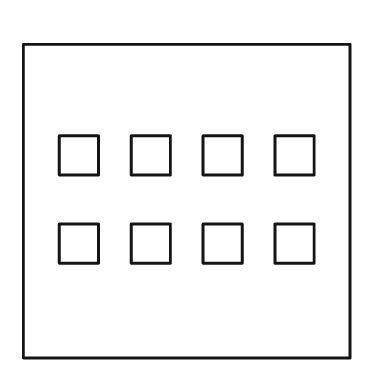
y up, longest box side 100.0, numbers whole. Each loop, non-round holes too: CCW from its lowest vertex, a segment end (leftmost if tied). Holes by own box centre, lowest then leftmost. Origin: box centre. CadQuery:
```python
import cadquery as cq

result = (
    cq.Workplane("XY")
    .moveTo(-50.0, -48.0)
    .lineTo(50.0, -48.0)
    .lineTo(50.0, 48.0)
    .lineTo(-50.0, 48.0)
    .close()
    .moveTo(-39.0, -19.0)
    .lineTo(-27.0, -19.0)
    .lineTo(-27.0, -7.0)
    .lineTo(-39.0, -7.0)
    .close()
    .moveTo(-17.0, -19.0)
    .lineTo(-5.0, -19.0)
    .lineTo(-5.0, -7.0)
    .lineTo(-17.0, -7.0)
    .close()
    .moveTo(5.0, -19.0)
    .lineTo(17.0, -19.0)
    .lineTo(17.0, -7.0)
    .lineTo(5.0, -7.0)
    .close()
    .moveTo(27.0, -19.0)
    .lineTo(39.0, -19.0)
    .lineTo(39.0, -7.0)
    .lineTo(27.0, -7.0)
    .close()
    .moveTo(-39.0, 8.0)
    .lineTo(-27.0, 8.0)
    .lineTo(-27.0, 20.0)
    .lineTo(-39.0, 20.0)
    .close()
    .moveTo(-17.0, 8.0)
    .lineTo(-5.0, 8.0)
    .lineTo(-5.0, 20.0)
    .lineTo(-17.0, 20.0)
    .close()
    .moveTo(5.0, 8.0)
    .lineTo(17.0, 8.0)
    .lineTo(17.0, 20.0)
    .lineTo(5.0, 20.0)
    .close()
    .moveTo(27.0, 8.0)
    .lineTo(39.0, 8.0)
    .lineTo(39.0, 20.0)
    .lineTo(27.0, 20.0)
    .close()
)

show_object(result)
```